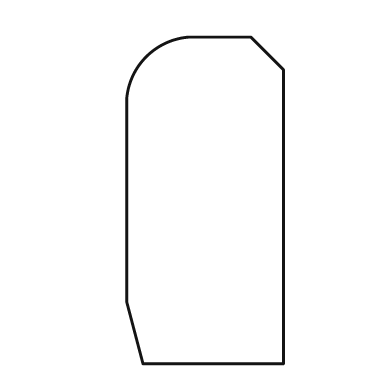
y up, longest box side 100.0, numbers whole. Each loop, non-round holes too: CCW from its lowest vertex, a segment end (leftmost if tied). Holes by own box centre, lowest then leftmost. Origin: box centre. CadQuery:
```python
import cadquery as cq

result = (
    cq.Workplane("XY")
    .moveTo(-19.0, -50.0)
    .lineTo(24.0, -50.0)
    .lineTo(24.0, 40.0)
    .lineTo(14.0, 50.0)
    .lineTo(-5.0, 50.0)
    .threePointArc((-18.0, 44.0), (-24.0, 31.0))
    .lineTo(-24.0, -31.0)
    .close()
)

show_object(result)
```